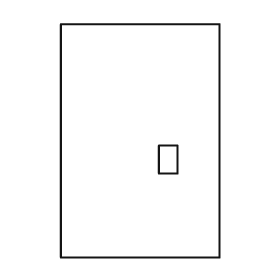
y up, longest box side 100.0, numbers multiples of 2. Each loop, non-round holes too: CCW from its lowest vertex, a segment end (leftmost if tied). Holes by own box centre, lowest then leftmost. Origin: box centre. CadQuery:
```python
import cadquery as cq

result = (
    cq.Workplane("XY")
    .moveTo(-34.0, -50.0)
    .lineTo(34.0, -50.0)
    .lineTo(34.0, 50.0)
    .lineTo(-34.0, 50.0)
    .close()
    .moveTo(8.0, -14.0)
    .lineTo(16.0, -14.0)
    .lineTo(16.0, -2.0)
    .lineTo(8.0, -2.0)
    .close()
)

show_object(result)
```